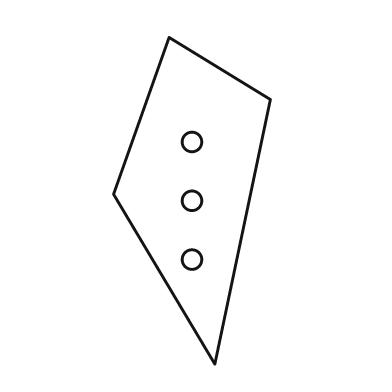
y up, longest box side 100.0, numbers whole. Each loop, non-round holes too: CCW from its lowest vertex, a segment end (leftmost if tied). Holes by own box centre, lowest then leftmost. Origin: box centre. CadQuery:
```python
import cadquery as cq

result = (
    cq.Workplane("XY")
    .moveTo(7.0, -50.0)
    .lineTo(24.0, 31.0)
    .lineTo(-7.0, 50.0)
    .lineTo(-24.0, 2.0)
    .close()
    .moveTo(0.0, -18.0)
    .circle(3.0)
    .moveTo(0.0, 0.0)
    .circle(3.0)
    .moveTo(0.0, 18.0)
    .circle(3.0)
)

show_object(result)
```